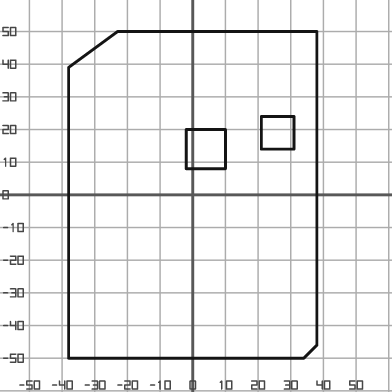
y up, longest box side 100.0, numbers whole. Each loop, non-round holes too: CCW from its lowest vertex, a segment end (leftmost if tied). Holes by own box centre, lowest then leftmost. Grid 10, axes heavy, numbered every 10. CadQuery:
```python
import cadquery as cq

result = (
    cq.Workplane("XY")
    .moveTo(-38.0, -50.0)
    .lineTo(34.0, -50.0)
    .lineTo(38.0, -46.0)
    .lineTo(38.0, 50.0)
    .lineTo(-23.0, 50.0)
    .lineTo(-38.0, 39.0)
    .close()
    .moveTo(-2.0, 8.0)
    .lineTo(10.0, 8.0)
    .lineTo(10.0, 20.0)
    .lineTo(-2.0, 20.0)
    .close()
    .moveTo(21.0, 14.0)
    .lineTo(31.0, 14.0)
    .lineTo(31.0, 24.0)
    .lineTo(21.0, 24.0)
    .close()
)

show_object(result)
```